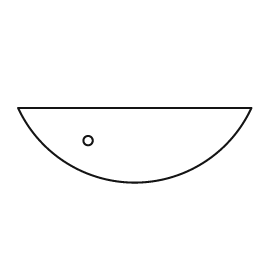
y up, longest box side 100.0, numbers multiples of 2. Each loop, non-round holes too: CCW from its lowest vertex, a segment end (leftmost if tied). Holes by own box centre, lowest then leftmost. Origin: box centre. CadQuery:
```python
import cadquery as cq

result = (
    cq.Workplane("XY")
    .moveTo(-50.0, 16.0)
    .threePointArc((0.0, -16.0), (50.0, 16.0))
    .close()
    .moveTo(-20.0, 2.0)
    .circle(2.0)
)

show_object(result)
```